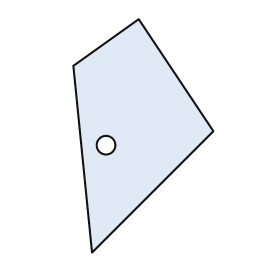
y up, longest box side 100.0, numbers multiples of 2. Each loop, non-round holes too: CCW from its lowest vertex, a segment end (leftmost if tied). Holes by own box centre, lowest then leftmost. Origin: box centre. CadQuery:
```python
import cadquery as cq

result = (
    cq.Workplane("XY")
    .moveTo(-22.0, -50.0)
    .lineTo(30.0, 2.0)
    .lineTo(-2.0, 50.0)
    .lineTo(-30.0, 30.0)
    .close()
    .moveTo(-16.0, -4.0)
    .circle(4.0)
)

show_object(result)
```